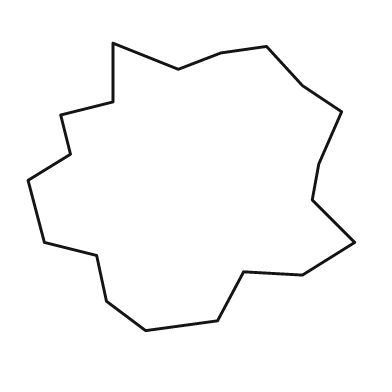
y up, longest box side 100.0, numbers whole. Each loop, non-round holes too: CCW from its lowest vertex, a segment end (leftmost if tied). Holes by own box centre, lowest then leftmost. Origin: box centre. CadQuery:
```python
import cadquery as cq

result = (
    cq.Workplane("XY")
    .moveTo(-14.0, -44.0)
    .lineTo(8.0, -41.0)
    .lineTo(16.0, -26.0)
    .lineTo(34.0, -27.0)
    .lineTo(50.0, -17.0)
    .lineTo(37.0, -4.0)
    .lineTo(39.0, 7.0)
    .lineTo(46.0, 23.0)
    .lineTo(34.0, 31.0)
    .lineTo(23.0, 43.0)
    .lineTo(9.0, 41.0)
    .lineTo(-4.0, 36.0)
    .lineTo(-24.0, 44.0)
    .lineTo(-24.0, 26.0)
    .lineTo(-40.0, 22.0)
    .lineTo(-37.0, 10.0)
    .lineTo(-50.0, 2.0)
    .lineTo(-45.0, -17.0)
    .lineTo(-29.0, -21.0)
    .lineTo(-26.0, -35.0)
    .close()
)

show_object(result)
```